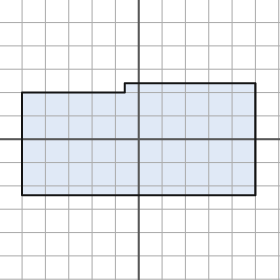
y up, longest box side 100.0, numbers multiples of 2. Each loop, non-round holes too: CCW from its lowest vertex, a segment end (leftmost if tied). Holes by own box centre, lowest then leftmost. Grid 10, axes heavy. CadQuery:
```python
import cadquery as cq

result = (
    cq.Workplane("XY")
    .moveTo(-50.0, -24.0)
    .lineTo(50.0, -24.0)
    .lineTo(50.0, 24.0)
    .lineTo(-6.0, 24.0)
    .lineTo(-6.0, 20.0)
    .lineTo(-50.0, 20.0)
    .close()
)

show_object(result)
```